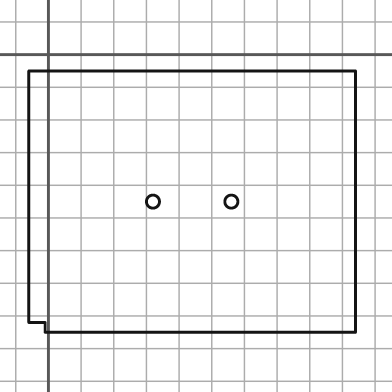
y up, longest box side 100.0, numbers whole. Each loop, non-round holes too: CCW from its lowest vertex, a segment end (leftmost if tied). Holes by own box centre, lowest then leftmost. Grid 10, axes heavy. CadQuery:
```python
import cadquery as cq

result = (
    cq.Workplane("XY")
    .moveTo(-1.0, -85.0)
    .lineTo(94.0, -85.0)
    .lineTo(94.0, -5.0)
    .lineTo(-6.0, -5.0)
    .lineTo(-6.0, -82.0)
    .lineTo(-1.0, -82.0)
    .close()
    .moveTo(32.0, -45.0)
    .circle(2.0)
    .moveTo(56.0, -45.0)
    .circle(2.0)
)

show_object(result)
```